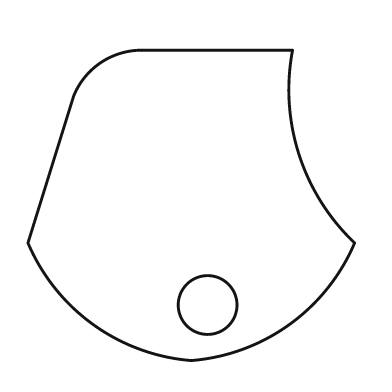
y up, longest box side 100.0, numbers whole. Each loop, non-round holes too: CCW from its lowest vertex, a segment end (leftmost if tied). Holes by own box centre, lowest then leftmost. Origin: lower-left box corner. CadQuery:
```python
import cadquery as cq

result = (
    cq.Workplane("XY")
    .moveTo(50.0, 0.0)
    .threePointArc((80.0, 11.0), (100.0, 36.0))
    .threePointArc((83.0, 63.0), (81.0, 95.0))
    .lineTo(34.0, 95.0)
    .threePointArc((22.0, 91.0), (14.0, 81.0))
    .lineTo(0.0, 36.0)
    .threePointArc((20.0, 11.0), (50.0, 0.0))
    .close()
    .moveTo(55.0, 17.0)
    .circle(9.0)
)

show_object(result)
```